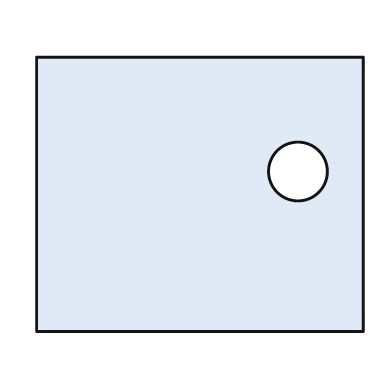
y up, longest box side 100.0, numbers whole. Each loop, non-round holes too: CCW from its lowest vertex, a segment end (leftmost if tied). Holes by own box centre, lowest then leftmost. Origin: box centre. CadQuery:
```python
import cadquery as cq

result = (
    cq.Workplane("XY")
    .moveTo(-50.0, -42.0)
    .lineTo(50.0, -42.0)
    .lineTo(50.0, 42.0)
    .lineTo(-50.0, 42.0)
    .close()
    .moveTo(30.0, 7.0)
    .circle(9.0)
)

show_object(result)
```